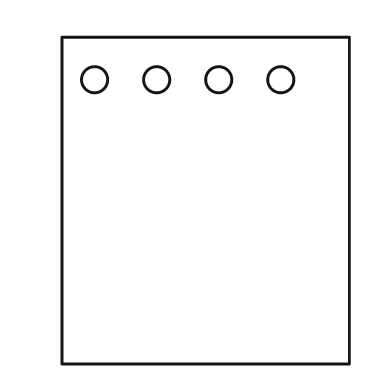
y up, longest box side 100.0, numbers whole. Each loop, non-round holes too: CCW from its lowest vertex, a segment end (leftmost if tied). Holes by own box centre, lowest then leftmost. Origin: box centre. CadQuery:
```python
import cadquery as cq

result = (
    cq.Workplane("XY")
    .moveTo(-44.0, -50.0)
    .lineTo(44.0, -50.0)
    .lineTo(44.0, 50.0)
    .lineTo(-44.0, 50.0)
    .close()
    .moveTo(-34.0, 37.0)
    .circle(4.0)
    .moveTo(-15.0, 37.0)
    .circle(4.0)
    .moveTo(4.0, 37.0)
    .circle(4.0)
    .moveTo(23.0, 37.0)
    .circle(4.0)
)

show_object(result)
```